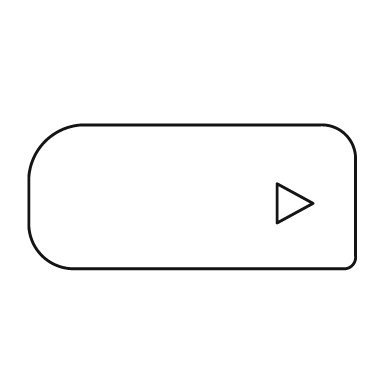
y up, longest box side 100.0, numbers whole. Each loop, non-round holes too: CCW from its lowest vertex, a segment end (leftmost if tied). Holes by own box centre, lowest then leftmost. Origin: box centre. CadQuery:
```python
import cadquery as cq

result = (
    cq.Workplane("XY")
    .moveTo(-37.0, -22.0)
    .lineTo(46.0, -22.0)
    .threePointArc((49.0, -21.0), (50.0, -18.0))
    .lineTo(50.0, 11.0)
    .threePointArc((47.0, 19.0), (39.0, 22.0))
    .lineTo(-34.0, 22.0)
    .threePointArc((-45.0, 17.0), (-50.0, 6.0))
    .lineTo(-50.0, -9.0)
    .threePointArc((-46.0, -18.0), (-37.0, -22.0))
    .close()
    .moveTo(26.0, -8.0)
    .lineTo(37.0, -2.0)
    .lineTo(26.0, 4.0)
    .close()
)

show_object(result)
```